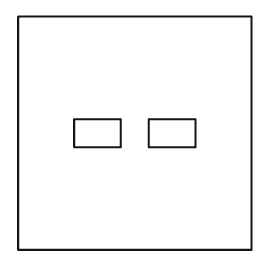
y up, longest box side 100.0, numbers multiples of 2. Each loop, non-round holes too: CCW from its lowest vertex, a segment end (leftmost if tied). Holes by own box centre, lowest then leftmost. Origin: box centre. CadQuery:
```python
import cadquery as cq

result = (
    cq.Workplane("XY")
    .moveTo(-50.0, -50.0)
    .lineTo(50.0, -50.0)
    .lineTo(50.0, 50.0)
    .lineTo(-50.0, 50.0)
    .close()
    .moveTo(-26.0, -6.0)
    .lineTo(-6.0, -6.0)
    .lineTo(-6.0, 6.0)
    .lineTo(-26.0, 6.0)
    .close()
    .moveTo(6.0, -6.0)
    .lineTo(26.0, -6.0)
    .lineTo(26.0, 6.0)
    .lineTo(6.0, 6.0)
    .close()
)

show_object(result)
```